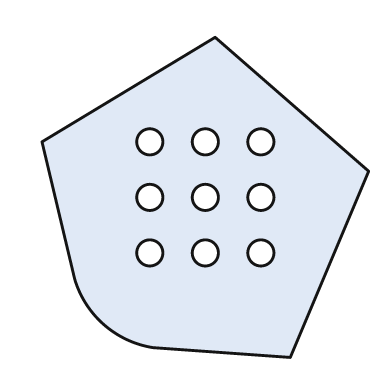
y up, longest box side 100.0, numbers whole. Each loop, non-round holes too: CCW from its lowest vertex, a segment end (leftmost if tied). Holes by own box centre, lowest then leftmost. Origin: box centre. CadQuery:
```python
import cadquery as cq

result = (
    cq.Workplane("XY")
    .moveTo(26.0, -49.0)
    .lineTo(50.0, 8.0)
    .lineTo(3.0, 49.0)
    .lineTo(-50.0, 17.0)
    .lineTo(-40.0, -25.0)
    .threePointArc((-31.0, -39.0), (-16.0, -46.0))
    .close()
    .moveTo(-17.0, -17.0)
    .circle(4.0)
    .moveTo(0.0, -17.0)
    .circle(4.0)
    .moveTo(17.0, -17.0)
    .circle(4.0)
    .moveTo(-17.0, 0.0)
    .circle(4.0)
    .moveTo(0.0, 0.0)
    .circle(4.0)
    .moveTo(17.0, 0.0)
    .circle(4.0)
    .moveTo(-17.0, 17.0)
    .circle(4.0)
    .moveTo(0.0, 17.0)
    .circle(4.0)
    .moveTo(17.0, 17.0)
    .circle(4.0)
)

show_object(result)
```